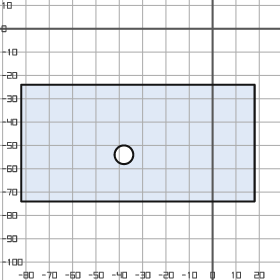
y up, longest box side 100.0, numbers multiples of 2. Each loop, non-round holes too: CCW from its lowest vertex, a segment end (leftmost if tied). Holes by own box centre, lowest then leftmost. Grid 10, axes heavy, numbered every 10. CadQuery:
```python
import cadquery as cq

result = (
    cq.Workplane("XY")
    .moveTo(-82.0, -74.0)
    .lineTo(18.0, -74.0)
    .lineTo(18.0, -24.0)
    .lineTo(-82.0, -24.0)
    .close()
    .moveTo(-38.0, -54.0)
    .circle(4.0)
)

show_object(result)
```